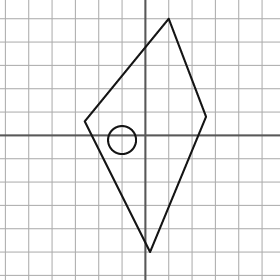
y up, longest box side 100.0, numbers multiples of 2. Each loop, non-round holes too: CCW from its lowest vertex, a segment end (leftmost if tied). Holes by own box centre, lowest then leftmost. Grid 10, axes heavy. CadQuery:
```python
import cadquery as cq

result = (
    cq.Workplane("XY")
    .moveTo(2.0, -50.0)
    .lineTo(26.0, 8.0)
    .lineTo(10.0, 50.0)
    .lineTo(-26.0, 6.0)
    .close()
    .moveTo(-10.0, -2.0)
    .circle(6.0)
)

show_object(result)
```